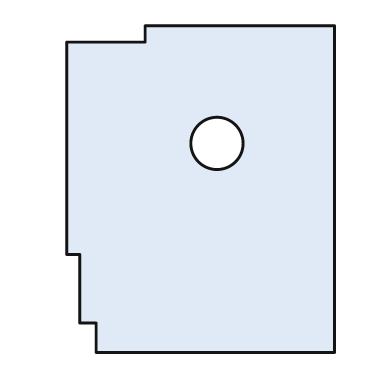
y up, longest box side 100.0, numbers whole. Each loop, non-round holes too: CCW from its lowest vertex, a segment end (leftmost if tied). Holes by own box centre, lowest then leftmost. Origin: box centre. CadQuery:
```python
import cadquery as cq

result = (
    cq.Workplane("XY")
    .moveTo(-32.0, -50.0)
    .lineTo(41.0, -50.0)
    .lineTo(41.0, 50.0)
    .lineTo(-17.0, 50.0)
    .lineTo(-17.0, 45.0)
    .lineTo(-41.0, 45.0)
    .lineTo(-41.0, -20.0)
    .lineTo(-37.0, -20.0)
    .lineTo(-37.0, -41.0)
    .lineTo(-32.0, -41.0)
    .close()
    .moveTo(5.0, 14.0)
    .circle(8.0)
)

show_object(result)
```